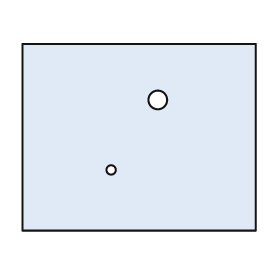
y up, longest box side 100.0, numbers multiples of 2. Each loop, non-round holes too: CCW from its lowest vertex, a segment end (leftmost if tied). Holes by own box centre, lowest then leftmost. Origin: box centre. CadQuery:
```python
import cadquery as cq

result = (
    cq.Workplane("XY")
    .moveTo(-50.0, -40.0)
    .lineTo(50.0, -40.0)
    .lineTo(50.0, 40.0)
    .lineTo(-50.0, 40.0)
    .close()
    .moveTo(-12.0, -14.0)
    .circle(2.0)
    .moveTo(8.0, 16.0)
    .circle(4.0)
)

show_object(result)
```